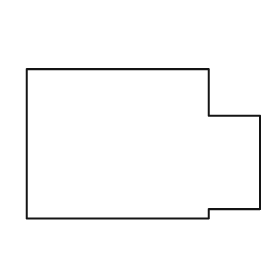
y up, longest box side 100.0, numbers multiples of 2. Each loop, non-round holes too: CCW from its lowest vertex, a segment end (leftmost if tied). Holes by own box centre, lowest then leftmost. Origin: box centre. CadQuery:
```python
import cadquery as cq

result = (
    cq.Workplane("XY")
    .moveTo(-50.0, -32.0)
    .lineTo(28.0, -32.0)
    .lineTo(28.0, -28.0)
    .lineTo(50.0, -28.0)
    .lineTo(50.0, 12.0)
    .lineTo(28.0, 12.0)
    .lineTo(28.0, 32.0)
    .lineTo(-50.0, 32.0)
    .close()
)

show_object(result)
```